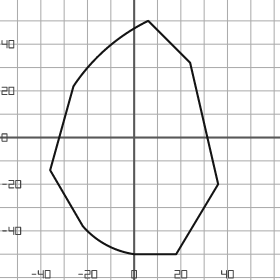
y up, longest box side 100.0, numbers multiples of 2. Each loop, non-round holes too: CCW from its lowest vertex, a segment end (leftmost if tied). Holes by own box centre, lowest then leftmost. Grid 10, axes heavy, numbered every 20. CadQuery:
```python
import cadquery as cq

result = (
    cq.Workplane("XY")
    .moveTo(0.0, -50.0)
    .lineTo(18.0, -50.0)
    .lineTo(36.0, -20.0)
    .lineTo(24.0, 32.0)
    .lineTo(6.0, 50.0)
    .threePointArc((-12.0, 38.0), (-26.0, 22.0))
    .lineTo(-36.0, -14.0)
    .lineTo(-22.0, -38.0)
    .threePointArc((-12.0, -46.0), (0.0, -50.0))
    .close()
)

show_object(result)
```